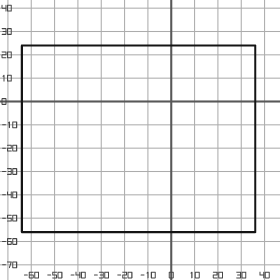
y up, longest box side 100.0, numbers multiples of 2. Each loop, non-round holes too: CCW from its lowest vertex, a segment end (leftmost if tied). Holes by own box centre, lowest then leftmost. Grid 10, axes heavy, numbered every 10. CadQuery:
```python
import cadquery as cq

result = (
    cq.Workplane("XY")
    .moveTo(-64.0, -56.0)
    .lineTo(36.0, -56.0)
    .lineTo(36.0, 24.0)
    .lineTo(-64.0, 24.0)
    .close()
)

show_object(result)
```